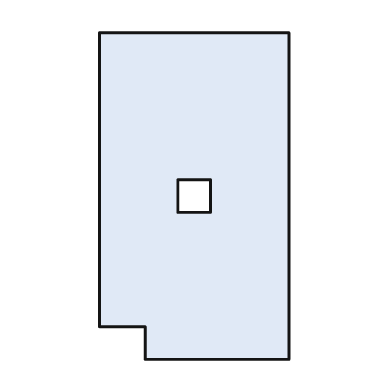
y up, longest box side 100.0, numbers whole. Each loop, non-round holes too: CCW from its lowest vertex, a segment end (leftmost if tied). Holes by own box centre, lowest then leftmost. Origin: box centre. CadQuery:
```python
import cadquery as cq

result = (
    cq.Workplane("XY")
    .moveTo(-15.0, -50.0)
    .lineTo(29.0, -50.0)
    .lineTo(29.0, 50.0)
    .lineTo(-29.0, 50.0)
    .lineTo(-29.0, -40.0)
    .lineTo(-15.0, -40.0)
    .close()
    .moveTo(-5.0, -5.0)
    .lineTo(5.0, -5.0)
    .lineTo(5.0, 5.0)
    .lineTo(-5.0, 5.0)
    .close()
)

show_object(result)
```